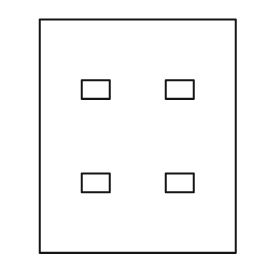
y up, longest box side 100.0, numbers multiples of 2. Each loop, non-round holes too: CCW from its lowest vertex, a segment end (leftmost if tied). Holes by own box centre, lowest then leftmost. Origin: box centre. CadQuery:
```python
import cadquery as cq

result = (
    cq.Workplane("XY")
    .moveTo(-42.0, -50.0)
    .lineTo(42.0, -50.0)
    .lineTo(42.0, 50.0)
    .lineTo(-42.0, 50.0)
    .close()
    .moveTo(-24.0, -24.0)
    .lineTo(-12.0, -24.0)
    .lineTo(-12.0, -16.0)
    .lineTo(-24.0, -16.0)
    .close()
    .moveTo(12.0, -24.0)
    .lineTo(24.0, -24.0)
    .lineTo(24.0, -16.0)
    .lineTo(12.0, -16.0)
    .close()
    .moveTo(-24.0, 16.0)
    .lineTo(-12.0, 16.0)
    .lineTo(-12.0, 24.0)
    .lineTo(-24.0, 24.0)
    .close()
    .moveTo(12.0, 16.0)
    .lineTo(24.0, 16.0)
    .lineTo(24.0, 24.0)
    .lineTo(12.0, 24.0)
    .close()
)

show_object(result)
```